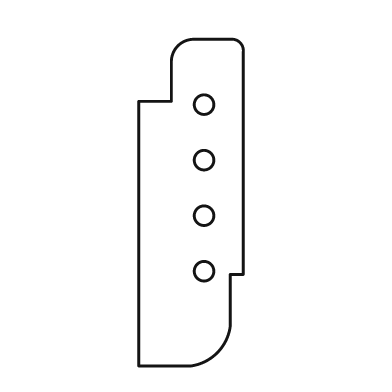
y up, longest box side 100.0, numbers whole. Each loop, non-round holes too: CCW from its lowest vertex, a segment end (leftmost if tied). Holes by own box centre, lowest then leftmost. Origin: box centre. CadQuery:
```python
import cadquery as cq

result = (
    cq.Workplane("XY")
    .moveTo(-16.0, -50.0)
    .lineTo(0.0, -50.0)
    .threePointArc((8.0, -46.0), (12.0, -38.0))
    .lineTo(12.0, -22.0)
    .lineTo(16.0, -22.0)
    .lineTo(16.0, 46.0)
    .threePointArc((15.0, 49.0), (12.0, 50.0))
    .lineTo(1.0, 50.0)
    .threePointArc((-4.0, 48.0), (-6.0, 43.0))
    .lineTo(-6.0, 31.0)
    .lineTo(-16.0, 31.0)
    .close()
    .moveTo(4.0, -21.0)
    .circle(3.0)
    .moveTo(4.0, -4.0)
    .circle(3.0)
    .moveTo(4.0, 13.0)
    .circle(3.0)
    .moveTo(4.0, 30.0)
    .circle(3.0)
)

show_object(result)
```